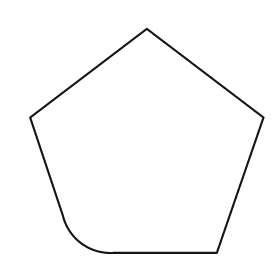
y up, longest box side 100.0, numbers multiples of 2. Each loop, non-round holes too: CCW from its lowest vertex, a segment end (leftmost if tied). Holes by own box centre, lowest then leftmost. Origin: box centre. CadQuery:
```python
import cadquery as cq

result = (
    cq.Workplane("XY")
    .moveTo(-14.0, -48.0)
    .lineTo(30.0, -48.0)
    .lineTo(50.0, 10.0)
    .lineTo(0.0, 48.0)
    .lineTo(-50.0, 10.0)
    .lineTo(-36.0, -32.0)
    .threePointArc((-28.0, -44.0), (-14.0, -48.0))
    .close()
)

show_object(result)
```